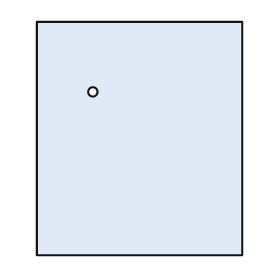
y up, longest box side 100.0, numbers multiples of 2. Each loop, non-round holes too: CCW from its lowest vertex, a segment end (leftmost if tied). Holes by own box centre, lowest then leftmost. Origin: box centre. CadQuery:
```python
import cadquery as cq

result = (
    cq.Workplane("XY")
    .moveTo(-44.0, -50.0)
    .lineTo(44.0, -50.0)
    .lineTo(44.0, 50.0)
    .lineTo(-44.0, 50.0)
    .close()
    .moveTo(-20.0, 20.0)
    .circle(2.0)
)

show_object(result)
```